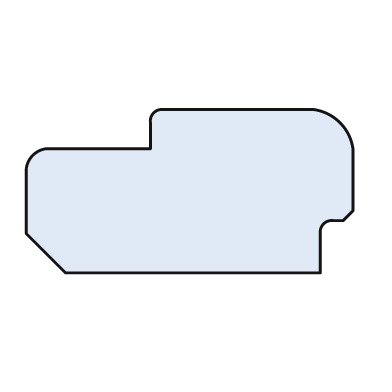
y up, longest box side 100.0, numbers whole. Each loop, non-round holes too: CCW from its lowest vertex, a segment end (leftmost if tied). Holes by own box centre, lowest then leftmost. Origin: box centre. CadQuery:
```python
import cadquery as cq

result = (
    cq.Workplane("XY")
    .moveTo(-38.0, -25.0)
    .lineTo(40.0, -25.0)
    .lineTo(40.0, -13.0)
    .threePointArc((41.0, -10.0), (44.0, -9.0))
    .lineTo(47.0, -9.0)
    .lineTo(50.0, -6.0)
    .lineTo(50.0, 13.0)
    .threePointArc((46.0, 21.0), (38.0, 25.0))
    .lineTo(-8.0, 25.0)
    .threePointArc((-11.0, 24.0), (-12.0, 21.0))
    .lineTo(-12.0, 13.0)
    .lineTo(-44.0, 13.0)
    .threePointArc((-48.0, 11.0), (-50.0, 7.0))
    .lineTo(-50.0, -13.0)
    .close()
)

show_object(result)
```